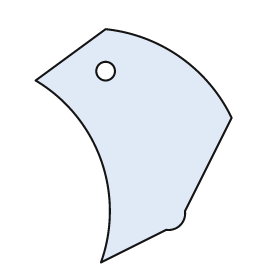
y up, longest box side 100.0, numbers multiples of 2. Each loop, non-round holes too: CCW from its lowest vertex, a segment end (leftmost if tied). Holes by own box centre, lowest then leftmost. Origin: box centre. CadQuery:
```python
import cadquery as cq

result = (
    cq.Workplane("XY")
    .moveTo(-14.0, -50.0)
    .lineTo(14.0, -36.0)
    .threePointArc((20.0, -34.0), (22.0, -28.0))
    .lineTo(42.0, 12.0)
    .threePointArc((20.0, 38.0), (-12.0, 50.0))
    .lineTo(-42.0, 28.0)
    .threePointArc((-14.0, -6.0), (-14.0, -50.0))
    .close()
    .moveTo(-12.0, 32.0)
    .circle(4.0)
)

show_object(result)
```